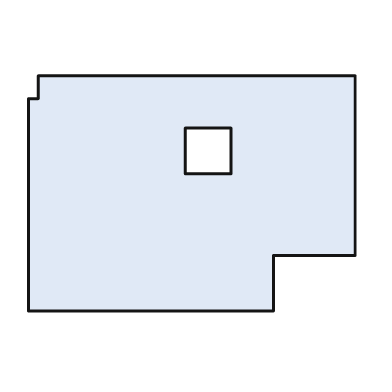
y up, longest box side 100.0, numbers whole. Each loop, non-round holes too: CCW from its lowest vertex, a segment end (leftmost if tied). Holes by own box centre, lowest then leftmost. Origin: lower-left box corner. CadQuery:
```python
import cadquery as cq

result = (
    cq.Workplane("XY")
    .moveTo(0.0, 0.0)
    .lineTo(75.0, 0.0)
    .lineTo(75.0, 17.0)
    .lineTo(100.0, 17.0)
    .lineTo(100.0, 72.0)
    .lineTo(3.0, 72.0)
    .lineTo(3.0, 65.0)
    .lineTo(0.0, 65.0)
    .close()
    .moveTo(48.0, 42.0)
    .lineTo(62.0, 42.0)
    .lineTo(62.0, 56.0)
    .lineTo(48.0, 56.0)
    .close()
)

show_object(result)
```